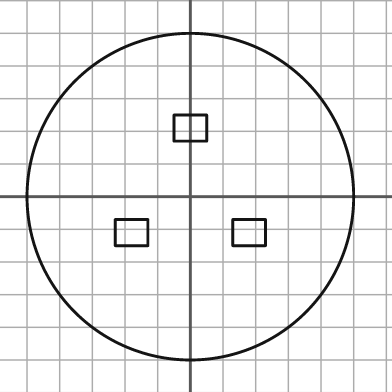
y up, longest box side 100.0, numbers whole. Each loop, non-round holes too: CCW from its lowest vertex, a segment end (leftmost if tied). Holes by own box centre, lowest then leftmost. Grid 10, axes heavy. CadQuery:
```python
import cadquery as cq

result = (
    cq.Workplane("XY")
    .moveTo(0.0, 0.0)
    .circle(50.0)
    .moveTo(-23.0, -15.0)
    .lineTo(-13.0, -15.0)
    .lineTo(-13.0, -7.0)
    .lineTo(-23.0, -7.0)
    .close()
    .moveTo(13.0, -15.0)
    .lineTo(23.0, -15.0)
    .lineTo(23.0, -7.0)
    .lineTo(13.0, -7.0)
    .close()
    .moveTo(-5.0, 17.0)
    .lineTo(5.0, 17.0)
    .lineTo(5.0, 25.0)
    .lineTo(-5.0, 25.0)
    .close()
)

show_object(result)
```